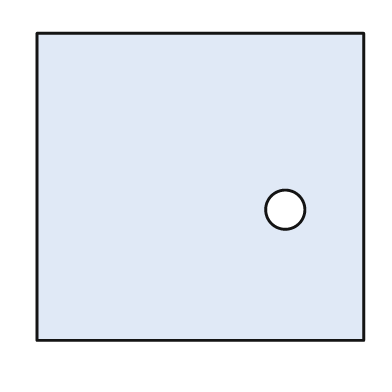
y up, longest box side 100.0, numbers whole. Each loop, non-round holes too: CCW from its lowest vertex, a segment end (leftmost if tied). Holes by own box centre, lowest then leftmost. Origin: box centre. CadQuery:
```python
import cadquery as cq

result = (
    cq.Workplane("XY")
    .moveTo(-50.0, -47.0)
    .lineTo(50.0, -47.0)
    .lineTo(50.0, 47.0)
    .lineTo(-50.0, 47.0)
    .close()
    .moveTo(26.0, -7.0)
    .circle(6.0)
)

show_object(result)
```